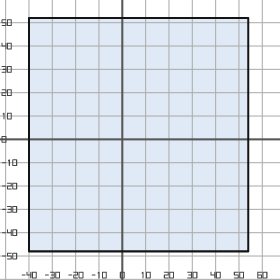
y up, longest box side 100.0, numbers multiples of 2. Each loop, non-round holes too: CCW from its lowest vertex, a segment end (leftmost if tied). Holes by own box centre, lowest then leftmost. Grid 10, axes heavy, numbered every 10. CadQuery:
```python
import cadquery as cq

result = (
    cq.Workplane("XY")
    .moveTo(-40.0, -48.0)
    .lineTo(54.0, -48.0)
    .lineTo(54.0, 52.0)
    .lineTo(-40.0, 52.0)
    .close()
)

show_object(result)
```